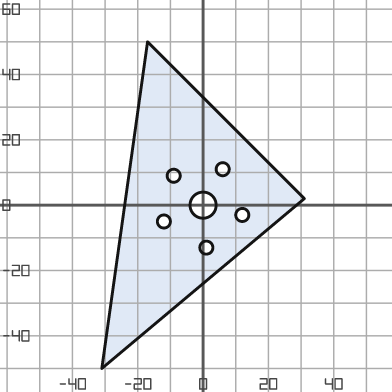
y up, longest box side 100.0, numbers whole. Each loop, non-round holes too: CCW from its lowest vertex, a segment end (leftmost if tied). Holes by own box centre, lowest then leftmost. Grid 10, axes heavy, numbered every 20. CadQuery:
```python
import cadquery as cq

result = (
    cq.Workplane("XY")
    .moveTo(-31.0, -50.0)
    .lineTo(31.0, 2.0)
    .lineTo(-17.0, 50.0)
    .close()
    .moveTo(1.0, -13.0)
    .circle(2.0)
    .moveTo(-12.0, -5.0)
    .circle(2.0)
    .moveTo(12.0, -3.0)
    .circle(2.0)
    .moveTo(0.0, 0.0)
    .circle(4.0)
    .moveTo(-9.0, 9.0)
    .circle(2.0)
    .moveTo(6.0, 11.0)
    .circle(2.0)
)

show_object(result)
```